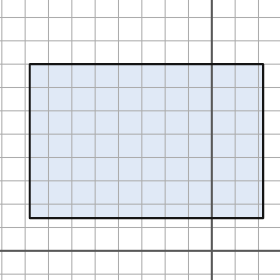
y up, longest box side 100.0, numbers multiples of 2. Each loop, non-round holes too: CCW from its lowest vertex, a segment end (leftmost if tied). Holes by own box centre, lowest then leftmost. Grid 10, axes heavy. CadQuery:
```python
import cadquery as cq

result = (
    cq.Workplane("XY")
    .moveTo(-78.0, 14.0)
    .lineTo(22.0, 14.0)
    .lineTo(22.0, 80.0)
    .lineTo(-78.0, 80.0)
    .close()
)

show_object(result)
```